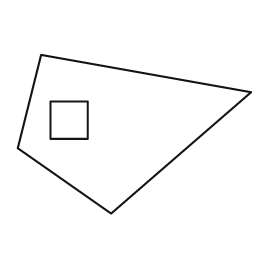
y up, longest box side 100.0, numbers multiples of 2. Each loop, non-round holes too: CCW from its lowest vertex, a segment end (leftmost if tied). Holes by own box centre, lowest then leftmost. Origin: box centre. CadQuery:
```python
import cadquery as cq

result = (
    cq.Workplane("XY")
    .moveTo(-10.0, -34.0)
    .lineTo(50.0, 18.0)
    .lineTo(-40.0, 34.0)
    .lineTo(-50.0, -6.0)
    .close()
    .moveTo(-36.0, -2.0)
    .lineTo(-20.0, -2.0)
    .lineTo(-20.0, 14.0)
    .lineTo(-36.0, 14.0)
    .close()
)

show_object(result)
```